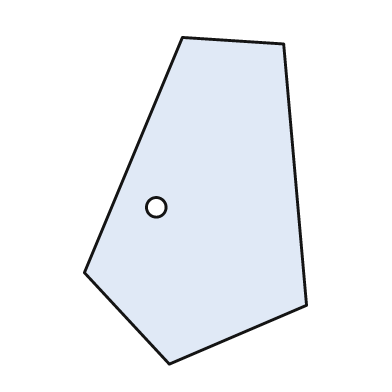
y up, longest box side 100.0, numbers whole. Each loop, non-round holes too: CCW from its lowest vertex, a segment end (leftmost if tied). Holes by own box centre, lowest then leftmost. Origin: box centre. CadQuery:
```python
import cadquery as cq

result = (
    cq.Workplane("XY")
    .moveTo(-8.0, -50.0)
    .lineTo(34.0, -32.0)
    .lineTo(27.0, 48.0)
    .lineTo(-4.0, 50.0)
    .lineTo(-34.0, -22.0)
    .close()
    .moveTo(-12.0, -2.0)
    .circle(3.0)
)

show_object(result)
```